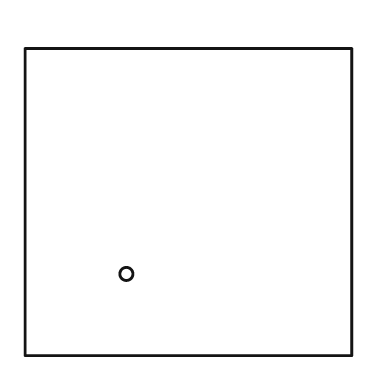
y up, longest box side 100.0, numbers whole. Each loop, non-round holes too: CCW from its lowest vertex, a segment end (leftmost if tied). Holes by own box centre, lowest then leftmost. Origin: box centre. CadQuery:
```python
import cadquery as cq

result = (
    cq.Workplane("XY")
    .moveTo(-50.0, -47.0)
    .lineTo(50.0, -47.0)
    .lineTo(50.0, 47.0)
    .lineTo(-50.0, 47.0)
    .close()
    .moveTo(-19.0, -22.0)
    .circle(2.0)
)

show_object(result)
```